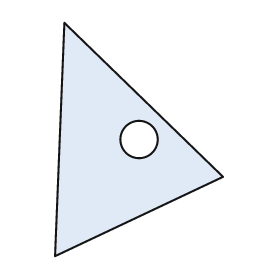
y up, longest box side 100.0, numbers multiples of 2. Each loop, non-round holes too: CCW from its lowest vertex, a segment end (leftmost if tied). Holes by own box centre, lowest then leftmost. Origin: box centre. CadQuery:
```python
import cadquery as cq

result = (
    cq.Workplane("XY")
    .moveTo(-36.0, -50.0)
    .lineTo(36.0, -16.0)
    .lineTo(-32.0, 50.0)
    .close()
    .moveTo(0.0, 0.0)
    .circle(8.0)
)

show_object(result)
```